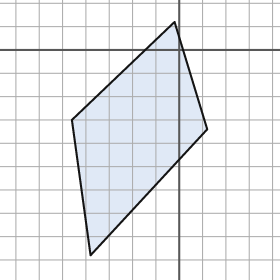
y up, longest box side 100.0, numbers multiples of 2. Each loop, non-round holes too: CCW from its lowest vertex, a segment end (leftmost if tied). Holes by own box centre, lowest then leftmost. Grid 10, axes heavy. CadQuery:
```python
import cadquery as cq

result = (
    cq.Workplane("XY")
    .moveTo(-38.0, -88.0)
    .lineTo(12.0, -34.0)
    .lineTo(-2.0, 12.0)
    .lineTo(-46.0, -30.0)
    .close()
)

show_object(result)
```